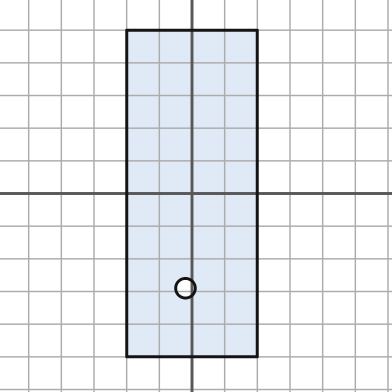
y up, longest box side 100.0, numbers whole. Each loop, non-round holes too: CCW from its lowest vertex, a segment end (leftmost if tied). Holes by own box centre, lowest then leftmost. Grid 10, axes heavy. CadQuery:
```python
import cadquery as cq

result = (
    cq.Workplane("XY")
    .moveTo(-20.0, -50.0)
    .lineTo(20.0, -50.0)
    .lineTo(20.0, 50.0)
    .lineTo(-20.0, 50.0)
    .close()
    .moveTo(-2.0, -29.0)
    .circle(3.0)
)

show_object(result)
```